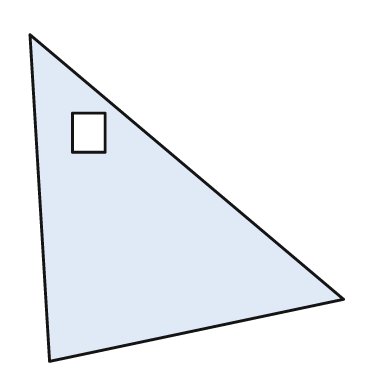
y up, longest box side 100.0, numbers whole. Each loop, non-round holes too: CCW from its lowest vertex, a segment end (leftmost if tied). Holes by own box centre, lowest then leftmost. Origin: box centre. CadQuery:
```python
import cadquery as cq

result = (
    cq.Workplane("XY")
    .moveTo(-42.0, -50.0)
    .lineTo(48.0, -31.0)
    .lineTo(-48.0, 50.0)
    .close()
    .moveTo(-35.0, 14.0)
    .lineTo(-25.0, 14.0)
    .lineTo(-25.0, 26.0)
    .lineTo(-35.0, 26.0)
    .close()
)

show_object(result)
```